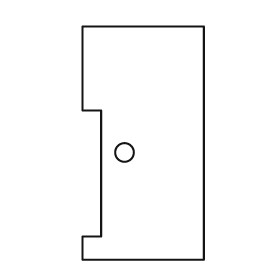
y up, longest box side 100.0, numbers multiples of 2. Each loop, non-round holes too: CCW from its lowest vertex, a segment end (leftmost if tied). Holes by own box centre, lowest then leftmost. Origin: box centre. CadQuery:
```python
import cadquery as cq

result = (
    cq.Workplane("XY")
    .moveTo(-26.0, -50.0)
    .lineTo(26.0, -50.0)
    .lineTo(26.0, 50.0)
    .lineTo(-26.0, 50.0)
    .lineTo(-26.0, 14.0)
    .lineTo(-18.0, 14.0)
    .lineTo(-18.0, -40.0)
    .lineTo(-26.0, -40.0)
    .close()
    .moveTo(-8.0, -4.0)
    .circle(4.0)
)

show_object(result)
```